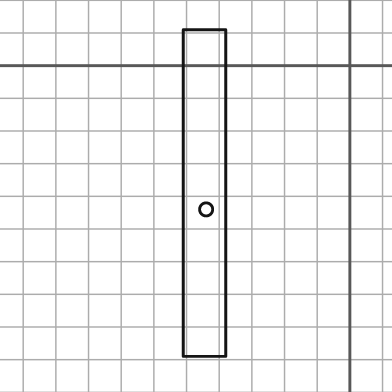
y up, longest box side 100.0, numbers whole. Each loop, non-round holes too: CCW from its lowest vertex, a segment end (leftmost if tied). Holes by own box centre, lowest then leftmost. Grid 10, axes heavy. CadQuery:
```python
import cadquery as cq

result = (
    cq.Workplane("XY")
    .moveTo(-51.0, -89.0)
    .lineTo(-38.0, -89.0)
    .lineTo(-38.0, 11.0)
    .lineTo(-51.0, 11.0)
    .close()
    .moveTo(-44.0, -44.0)
    .circle(2.0)
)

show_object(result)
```